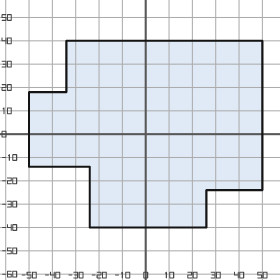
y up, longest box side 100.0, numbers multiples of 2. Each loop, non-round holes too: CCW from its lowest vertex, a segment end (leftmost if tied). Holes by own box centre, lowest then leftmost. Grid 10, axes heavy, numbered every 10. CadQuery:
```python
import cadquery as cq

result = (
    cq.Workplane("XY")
    .moveTo(-24.0, -40.0)
    .lineTo(26.0, -40.0)
    .lineTo(26.0, -24.0)
    .lineTo(50.0, -24.0)
    .lineTo(50.0, 40.0)
    .lineTo(-34.0, 40.0)
    .lineTo(-34.0, 18.0)
    .lineTo(-50.0, 18.0)
    .lineTo(-50.0, -14.0)
    .lineTo(-24.0, -14.0)
    .close()
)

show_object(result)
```